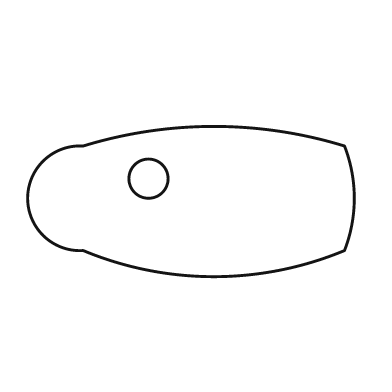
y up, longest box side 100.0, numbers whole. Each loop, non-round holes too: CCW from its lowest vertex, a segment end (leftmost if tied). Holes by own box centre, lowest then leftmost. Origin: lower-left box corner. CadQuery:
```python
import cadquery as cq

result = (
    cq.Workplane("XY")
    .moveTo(17.0, 8.0)
    .threePointArc((57.0, 0.0), (97.0, 8.0))
    .threePointArc((100.0, 24.0), (97.0, 40.0))
    .threePointArc((57.0, 46.0), (17.0, 40.0))
    .threePointArc((0.0, 24.0), (17.0, 8.0))
    .close()
    .moveTo(37.0, 30.0)
    .circle(6.0)
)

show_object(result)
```